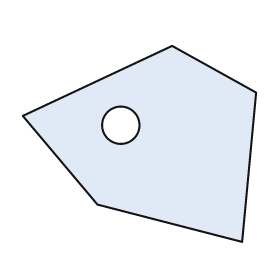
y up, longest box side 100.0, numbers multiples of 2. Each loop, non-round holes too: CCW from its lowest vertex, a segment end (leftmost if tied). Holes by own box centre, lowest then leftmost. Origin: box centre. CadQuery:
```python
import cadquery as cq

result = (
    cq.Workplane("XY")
    .moveTo(44.0, -42.0)
    .lineTo(50.0, 22.0)
    .lineTo(14.0, 42.0)
    .lineTo(-50.0, 12.0)
    .lineTo(-18.0, -26.0)
    .close()
    .moveTo(-8.0, 8.0)
    .circle(8.0)
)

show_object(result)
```